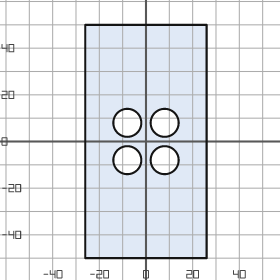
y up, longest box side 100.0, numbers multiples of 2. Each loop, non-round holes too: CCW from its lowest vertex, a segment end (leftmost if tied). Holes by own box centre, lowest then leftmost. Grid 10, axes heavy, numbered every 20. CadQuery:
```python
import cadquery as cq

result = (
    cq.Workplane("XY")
    .moveTo(-26.0, -50.0)
    .lineTo(26.0, -50.0)
    .lineTo(26.0, 50.0)
    .lineTo(-26.0, 50.0)
    .close()
    .moveTo(-8.0, -8.0)
    .circle(6.0)
    .moveTo(8.0, -8.0)
    .circle(6.0)
    .moveTo(-8.0, 8.0)
    .circle(6.0)
    .moveTo(8.0, 8.0)
    .circle(6.0)
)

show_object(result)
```